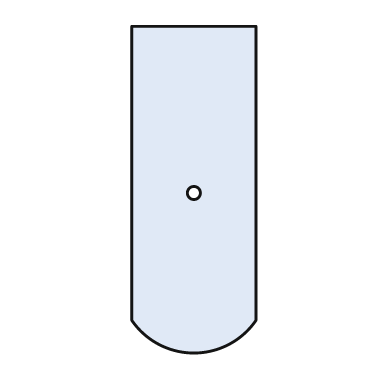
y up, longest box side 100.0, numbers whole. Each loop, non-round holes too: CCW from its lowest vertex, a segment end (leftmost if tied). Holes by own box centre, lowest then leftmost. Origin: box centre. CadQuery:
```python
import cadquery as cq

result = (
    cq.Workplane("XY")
    .moveTo(-19.0, -40.0)
    .threePointArc((0.0, -50.0), (19.0, -40.0))
    .lineTo(19.0, 50.0)
    .lineTo(-19.0, 50.0)
    .close()
    .moveTo(0.0, -1.0)
    .circle(2.0)
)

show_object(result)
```